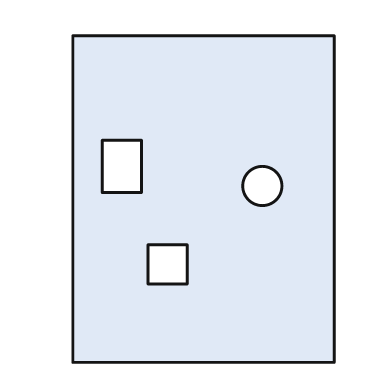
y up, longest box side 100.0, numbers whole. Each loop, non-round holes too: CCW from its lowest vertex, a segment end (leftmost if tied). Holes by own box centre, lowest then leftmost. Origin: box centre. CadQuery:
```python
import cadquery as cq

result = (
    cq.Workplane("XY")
    .moveTo(-40.0, -50.0)
    .lineTo(40.0, -50.0)
    .lineTo(40.0, 50.0)
    .lineTo(-40.0, 50.0)
    .close()
    .moveTo(-17.0, -26.0)
    .lineTo(-5.0, -26.0)
    .lineTo(-5.0, -14.0)
    .lineTo(-17.0, -14.0)
    .close()
    .moveTo(18.0, 4.0)
    .circle(6.0)
    .moveTo(-31.0, 2.0)
    .lineTo(-19.0, 2.0)
    .lineTo(-19.0, 18.0)
    .lineTo(-31.0, 18.0)
    .close()
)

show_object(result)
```